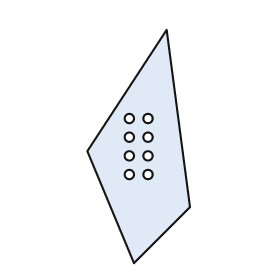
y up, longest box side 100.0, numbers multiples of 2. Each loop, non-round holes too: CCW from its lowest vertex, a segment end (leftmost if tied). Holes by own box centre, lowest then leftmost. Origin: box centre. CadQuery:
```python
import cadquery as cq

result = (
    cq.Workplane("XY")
    .moveTo(-2.0, -50.0)
    .lineTo(22.0, -26.0)
    .lineTo(12.0, 50.0)
    .lineTo(-22.0, -2.0)
    .close()
    .moveTo(-4.0, -12.0)
    .circle(2.0)
    .moveTo(4.0, -12.0)
    .circle(2.0)
    .moveTo(-4.0, -4.0)
    .circle(2.0)
    .moveTo(4.0, -4.0)
    .circle(2.0)
    .moveTo(-4.0, 4.0)
    .circle(2.0)
    .moveTo(4.0, 4.0)
    .circle(2.0)
    .moveTo(-4.0, 12.0)
    .circle(2.0)
    .moveTo(4.0, 12.0)
    .circle(2.0)
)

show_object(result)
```